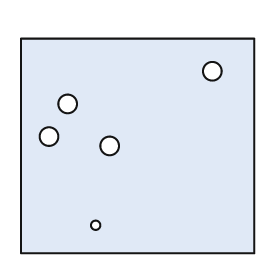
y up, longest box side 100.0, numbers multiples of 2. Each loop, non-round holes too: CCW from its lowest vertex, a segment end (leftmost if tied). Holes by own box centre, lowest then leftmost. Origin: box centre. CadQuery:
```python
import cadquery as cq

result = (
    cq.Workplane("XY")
    .moveTo(-50.0, -46.0)
    .lineTo(50.0, -46.0)
    .lineTo(50.0, 46.0)
    .lineTo(-50.0, 46.0)
    .close()
    .moveTo(-18.0, -34.0)
    .circle(2.0)
    .moveTo(-12.0, 0.0)
    .circle(4.0)
    .moveTo(-38.0, 4.0)
    .circle(4.0)
    .moveTo(-30.0, 18.0)
    .circle(4.0)
    .moveTo(32.0, 32.0)
    .circle(4.0)
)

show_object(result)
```